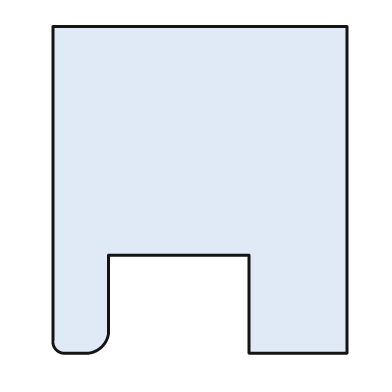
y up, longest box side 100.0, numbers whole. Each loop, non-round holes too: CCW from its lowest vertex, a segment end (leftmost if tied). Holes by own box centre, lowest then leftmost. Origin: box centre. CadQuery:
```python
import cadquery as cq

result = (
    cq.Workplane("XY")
    .moveTo(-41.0, -50.0)
    .lineTo(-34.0, -50.0)
    .threePointArc((-30.0, -48.0), (-28.0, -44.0))
    .lineTo(-28.0, -20.0)
    .lineTo(15.0, -20.0)
    .lineTo(15.0, -50.0)
    .lineTo(45.0, -50.0)
    .lineTo(45.0, 50.0)
    .lineTo(-45.0, 50.0)
    .lineTo(-45.0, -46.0)
    .threePointArc((-44.0, -49.0), (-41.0, -50.0))
    .close()
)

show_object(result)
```